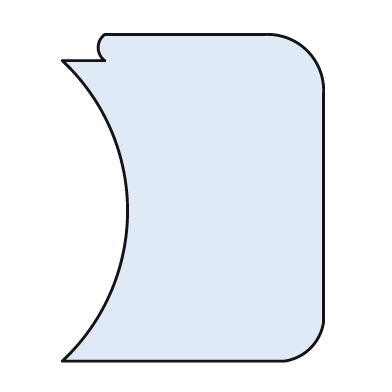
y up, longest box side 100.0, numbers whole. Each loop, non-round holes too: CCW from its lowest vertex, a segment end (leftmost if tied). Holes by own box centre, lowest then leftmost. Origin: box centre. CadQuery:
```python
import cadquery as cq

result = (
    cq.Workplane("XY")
    .moveTo(-40.0, -50.0)
    .lineTo(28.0, -50.0)
    .threePointArc((36.0, -46.0), (40.0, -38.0))
    .lineTo(40.0, 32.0)
    .threePointArc((35.0, 45.0), (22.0, 50.0))
    .lineTo(-27.0, 50.0)
    .threePointArc((-29.0, 46.0), (-27.0, 42.0))
    .lineTo(-40.0, 42.0)
    .threePointArc((-20.0, -4.0), (-40.0, -50.0))
    .close()
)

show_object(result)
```